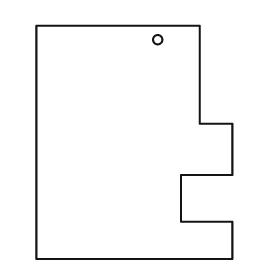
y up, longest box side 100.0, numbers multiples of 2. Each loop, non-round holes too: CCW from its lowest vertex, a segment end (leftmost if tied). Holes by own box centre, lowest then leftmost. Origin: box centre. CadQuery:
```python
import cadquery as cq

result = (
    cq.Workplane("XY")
    .moveTo(-42.0, -50.0)
    .lineTo(42.0, -50.0)
    .lineTo(42.0, -34.0)
    .lineTo(20.0, -34.0)
    .lineTo(20.0, -14.0)
    .lineTo(42.0, -14.0)
    .lineTo(42.0, 8.0)
    .lineTo(28.0, 8.0)
    .lineTo(28.0, 50.0)
    .lineTo(-42.0, 50.0)
    .close()
    .moveTo(10.0, 44.0)
    .circle(2.0)
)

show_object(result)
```